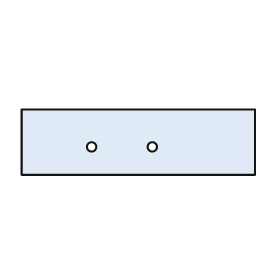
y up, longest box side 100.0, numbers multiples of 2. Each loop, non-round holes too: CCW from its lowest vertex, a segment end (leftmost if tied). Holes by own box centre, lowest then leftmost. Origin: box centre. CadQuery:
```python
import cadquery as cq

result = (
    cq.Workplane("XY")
    .moveTo(-50.0, -14.0)
    .lineTo(50.0, -14.0)
    .lineTo(50.0, 14.0)
    .lineTo(-50.0, 14.0)
    .close()
    .moveTo(-20.0, -2.0)
    .circle(2.0)
    .moveTo(6.0, -2.0)
    .circle(2.0)
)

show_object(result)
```